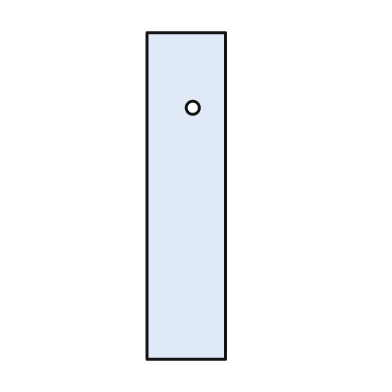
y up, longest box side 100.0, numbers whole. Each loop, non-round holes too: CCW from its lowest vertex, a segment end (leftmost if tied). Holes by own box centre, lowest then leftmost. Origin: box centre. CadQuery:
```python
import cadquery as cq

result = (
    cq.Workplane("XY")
    .moveTo(-12.0, -50.0)
    .lineTo(12.0, -50.0)
    .lineTo(12.0, 50.0)
    .lineTo(-12.0, 50.0)
    .close()
    .moveTo(2.0, 27.0)
    .circle(2.0)
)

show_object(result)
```